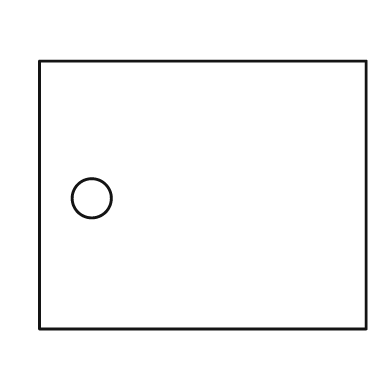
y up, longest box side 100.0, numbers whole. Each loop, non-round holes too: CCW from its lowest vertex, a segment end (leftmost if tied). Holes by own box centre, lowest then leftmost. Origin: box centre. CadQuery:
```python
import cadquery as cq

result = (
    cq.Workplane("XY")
    .moveTo(-50.0, -41.0)
    .lineTo(50.0, -41.0)
    .lineTo(50.0, 41.0)
    .lineTo(-50.0, 41.0)
    .close()
    .moveTo(-34.0, -1.0)
    .circle(6.0)
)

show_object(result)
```